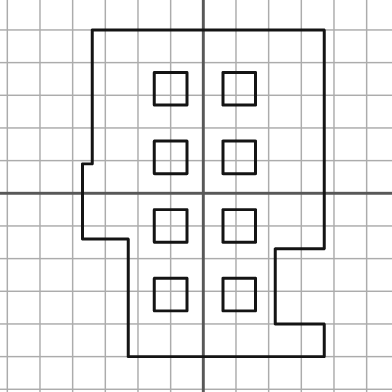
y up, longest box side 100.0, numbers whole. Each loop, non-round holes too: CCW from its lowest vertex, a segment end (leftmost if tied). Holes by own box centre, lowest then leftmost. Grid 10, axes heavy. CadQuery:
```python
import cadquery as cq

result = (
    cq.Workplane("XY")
    .moveTo(-23.0, -50.0)
    .lineTo(37.0, -50.0)
    .lineTo(37.0, -40.0)
    .lineTo(22.0, -40.0)
    .lineTo(22.0, -17.0)
    .lineTo(37.0, -17.0)
    .lineTo(37.0, 50.0)
    .lineTo(-34.0, 50.0)
    .lineTo(-34.0, 9.0)
    .lineTo(-37.0, 9.0)
    .lineTo(-37.0, -14.0)
    .lineTo(-23.0, -14.0)
    .close()
    .moveTo(-15.0, -36.0)
    .lineTo(-5.0, -36.0)
    .lineTo(-5.0, -26.0)
    .lineTo(-15.0, -26.0)
    .close()
    .moveTo(6.0, -36.0)
    .lineTo(16.0, -36.0)
    .lineTo(16.0, -26.0)
    .lineTo(6.0, -26.0)
    .close()
    .moveTo(-15.0, -15.0)
    .lineTo(-5.0, -15.0)
    .lineTo(-5.0, -5.0)
    .lineTo(-15.0, -5.0)
    .close()
    .moveTo(6.0, -15.0)
    .lineTo(16.0, -15.0)
    .lineTo(16.0, -5.0)
    .lineTo(6.0, -5.0)
    .close()
    .moveTo(-15.0, 6.0)
    .lineTo(-5.0, 6.0)
    .lineTo(-5.0, 16.0)
    .lineTo(-15.0, 16.0)
    .close()
    .moveTo(6.0, 6.0)
    .lineTo(16.0, 6.0)
    .lineTo(16.0, 16.0)
    .lineTo(6.0, 16.0)
    .close()
    .moveTo(-15.0, 27.0)
    .lineTo(-5.0, 27.0)
    .lineTo(-5.0, 37.0)
    .lineTo(-15.0, 37.0)
    .close()
    .moveTo(6.0, 27.0)
    .lineTo(16.0, 27.0)
    .lineTo(16.0, 37.0)
    .lineTo(6.0, 37.0)
    .close()
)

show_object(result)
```